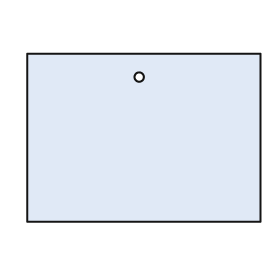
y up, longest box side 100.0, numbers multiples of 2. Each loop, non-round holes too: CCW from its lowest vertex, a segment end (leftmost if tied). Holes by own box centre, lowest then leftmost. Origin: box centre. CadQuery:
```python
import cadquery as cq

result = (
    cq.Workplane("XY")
    .moveTo(-50.0, -36.0)
    .lineTo(50.0, -36.0)
    .lineTo(50.0, 36.0)
    .lineTo(-50.0, 36.0)
    .close()
    .moveTo(-2.0, 26.0)
    .circle(2.0)
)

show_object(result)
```